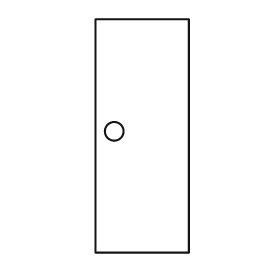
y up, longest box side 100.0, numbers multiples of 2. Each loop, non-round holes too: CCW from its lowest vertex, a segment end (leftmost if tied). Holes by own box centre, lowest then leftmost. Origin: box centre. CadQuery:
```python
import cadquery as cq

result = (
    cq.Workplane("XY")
    .moveTo(-20.0, -50.0)
    .lineTo(20.0, -50.0)
    .lineTo(20.0, 50.0)
    .lineTo(-20.0, 50.0)
    .close()
    .moveTo(-12.0, 2.0)
    .circle(4.0)
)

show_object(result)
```